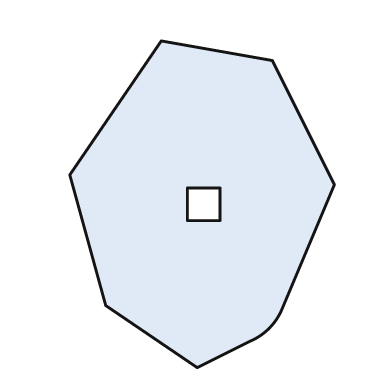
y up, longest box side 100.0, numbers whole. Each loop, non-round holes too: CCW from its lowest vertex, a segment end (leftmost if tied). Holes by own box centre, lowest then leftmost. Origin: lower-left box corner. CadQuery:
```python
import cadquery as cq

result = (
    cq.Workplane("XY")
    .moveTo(39.0, 0.0)
    .lineTo(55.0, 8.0)
    .threePointArc((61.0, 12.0), (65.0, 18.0))
    .lineTo(81.0, 56.0)
    .lineTo(62.0, 94.0)
    .lineTo(28.0, 100.0)
    .lineTo(0.0, 59.0)
    .lineTo(11.0, 19.0)
    .close()
    .moveTo(36.0, 45.0)
    .lineTo(46.0, 45.0)
    .lineTo(46.0, 55.0)
    .lineTo(36.0, 55.0)
    .close()
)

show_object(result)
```